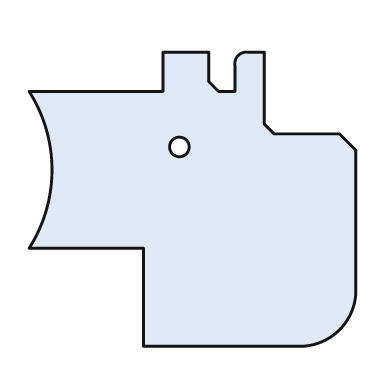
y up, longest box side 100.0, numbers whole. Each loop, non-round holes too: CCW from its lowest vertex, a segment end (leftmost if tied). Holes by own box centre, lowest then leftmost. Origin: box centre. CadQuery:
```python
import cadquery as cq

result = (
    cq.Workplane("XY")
    .moveTo(-15.0, -45.0)
    .lineTo(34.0, -45.0)
    .threePointArc((45.0, -40.0), (50.0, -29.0))
    .lineTo(50.0, 15.0)
    .lineTo(45.0, 20.0)
    .lineTo(25.0, 20.0)
    .lineTo(22.0, 23.0)
    .lineTo(22.0, 45.0)
    .lineTo(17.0, 45.0)
    .threePointArc((14.0, 44.0), (13.0, 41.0))
    .lineTo(13.0, 33.0)
    .lineTo(8.0, 33.0)
    .lineTo(5.0, 36.0)
    .lineTo(5.0, 45.0)
    .lineTo(-9.0, 45.0)
    .lineTo(-9.0, 33.0)
    .lineTo(-50.0, 33.0)
    .threePointArc((-43.0, 9.0), (-50.0, -15.0))
    .lineTo(-15.0, -15.0)
    .close()
    .moveTo(-4.0, 16.0)
    .circle(3.0)
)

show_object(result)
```